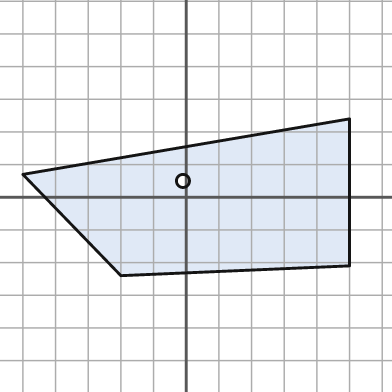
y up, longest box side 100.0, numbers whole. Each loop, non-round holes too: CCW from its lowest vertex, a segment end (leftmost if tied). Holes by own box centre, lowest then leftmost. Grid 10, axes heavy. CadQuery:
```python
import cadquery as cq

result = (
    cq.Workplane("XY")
    .moveTo(-20.0, -24.0)
    .lineTo(50.0, -21.0)
    .lineTo(50.0, 24.0)
    .lineTo(-50.0, 7.0)
    .close()
    .moveTo(-1.0, 5.0)
    .circle(2.0)
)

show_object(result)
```